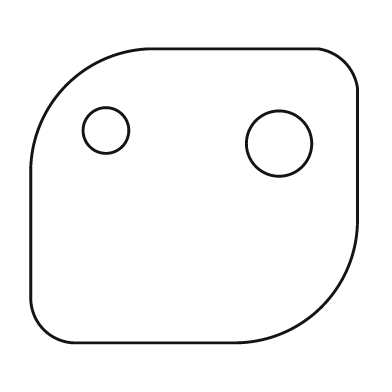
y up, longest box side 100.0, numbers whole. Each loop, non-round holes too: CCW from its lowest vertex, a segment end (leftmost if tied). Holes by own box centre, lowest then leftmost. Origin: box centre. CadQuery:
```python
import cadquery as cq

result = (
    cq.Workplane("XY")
    .moveTo(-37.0, -45.0)
    .lineTo(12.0, -45.0)
    .threePointArc((39.0, -34.0), (50.0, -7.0))
    .lineTo(50.0, 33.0)
    .threePointArc((46.0, 41.0), (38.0, 45.0))
    .lineTo(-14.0, 45.0)
    .threePointArc((-39.0, 34.0), (-50.0, 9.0))
    .lineTo(-50.0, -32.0)
    .threePointArc((-46.0, -41.0), (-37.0, -45.0))
    .close()
    .moveTo(26.0, 16.0)
    .circle(10.0)
    .moveTo(-27.0, 20.0)
    .circle(7.0)
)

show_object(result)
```